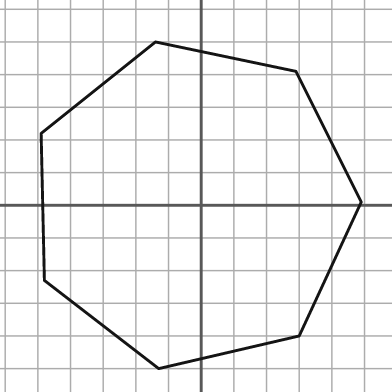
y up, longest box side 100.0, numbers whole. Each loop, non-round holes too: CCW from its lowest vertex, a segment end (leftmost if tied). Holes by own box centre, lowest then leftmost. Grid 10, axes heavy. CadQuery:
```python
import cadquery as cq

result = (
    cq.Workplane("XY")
    .moveTo(-13.0, -50.0)
    .lineTo(30.0, -40.0)
    .lineTo(49.0, 1.0)
    .lineTo(29.0, 41.0)
    .lineTo(-14.0, 50.0)
    .lineTo(-49.0, 22.0)
    .lineTo(-48.0, -23.0)
    .close()
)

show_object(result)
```